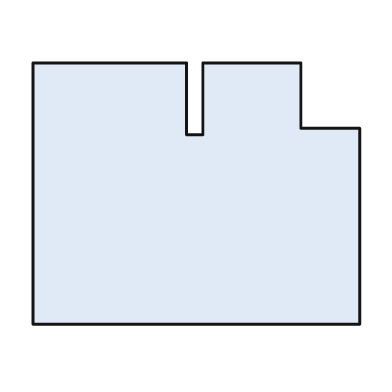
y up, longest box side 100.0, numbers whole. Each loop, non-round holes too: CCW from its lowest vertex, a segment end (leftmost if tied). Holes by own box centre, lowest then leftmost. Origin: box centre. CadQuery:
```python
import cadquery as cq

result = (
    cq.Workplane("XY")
    .moveTo(-50.0, -40.0)
    .lineTo(50.0, -40.0)
    .lineTo(50.0, 20.0)
    .lineTo(32.0, 20.0)
    .lineTo(32.0, 40.0)
    .lineTo(2.0, 40.0)
    .lineTo(2.0, 18.0)
    .lineTo(-3.0, 18.0)
    .lineTo(-3.0, 40.0)
    .lineTo(-50.0, 40.0)
    .close()
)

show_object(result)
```